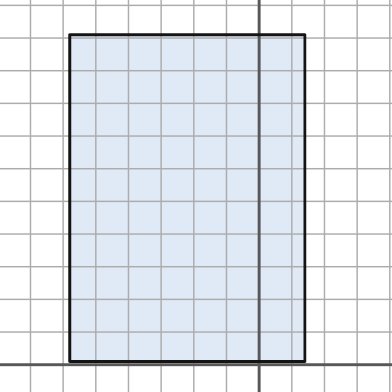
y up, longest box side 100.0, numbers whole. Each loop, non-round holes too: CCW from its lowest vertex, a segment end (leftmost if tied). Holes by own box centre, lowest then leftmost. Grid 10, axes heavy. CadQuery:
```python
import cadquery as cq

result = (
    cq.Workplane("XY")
    .moveTo(-58.0, 1.0)
    .lineTo(14.0, 1.0)
    .lineTo(14.0, 101.0)
    .lineTo(-58.0, 101.0)
    .close()
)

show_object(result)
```